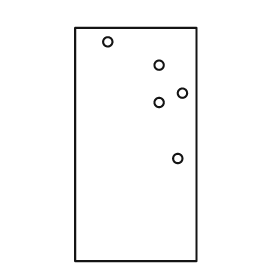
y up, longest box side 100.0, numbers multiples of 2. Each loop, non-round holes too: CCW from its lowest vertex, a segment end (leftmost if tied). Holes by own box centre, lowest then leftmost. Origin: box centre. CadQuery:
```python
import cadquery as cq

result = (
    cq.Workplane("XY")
    .moveTo(-26.0, -50.0)
    .lineTo(26.0, -50.0)
    .lineTo(26.0, 50.0)
    .lineTo(-26.0, 50.0)
    .close()
    .moveTo(18.0, -6.0)
    .circle(2.0)
    .moveTo(10.0, 18.0)
    .circle(2.0)
    .moveTo(20.0, 22.0)
    .circle(2.0)
    .moveTo(10.0, 34.0)
    .circle(2.0)
    .moveTo(-12.0, 44.0)
    .circle(2.0)
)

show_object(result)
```